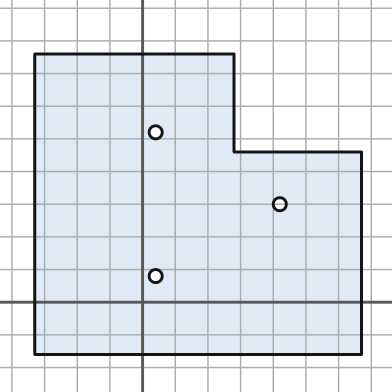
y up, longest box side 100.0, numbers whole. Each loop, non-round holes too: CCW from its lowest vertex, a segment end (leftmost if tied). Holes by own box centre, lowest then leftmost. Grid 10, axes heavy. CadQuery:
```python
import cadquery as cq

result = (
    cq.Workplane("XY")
    .moveTo(-33.0, -16.0)
    .lineTo(67.0, -16.0)
    .lineTo(67.0, 46.0)
    .lineTo(28.0, 46.0)
    .lineTo(28.0, 76.0)
    .lineTo(-33.0, 76.0)
    .close()
    .moveTo(4.0, 8.0)
    .circle(2.0)
    .moveTo(42.0, 30.0)
    .circle(2.0)
    .moveTo(4.0, 52.0)
    .circle(2.0)
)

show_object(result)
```